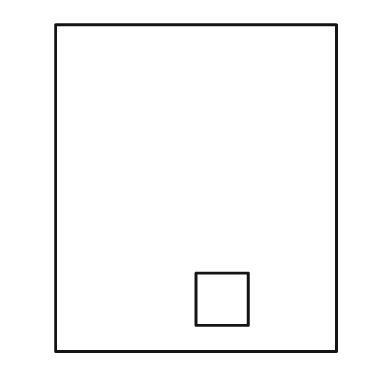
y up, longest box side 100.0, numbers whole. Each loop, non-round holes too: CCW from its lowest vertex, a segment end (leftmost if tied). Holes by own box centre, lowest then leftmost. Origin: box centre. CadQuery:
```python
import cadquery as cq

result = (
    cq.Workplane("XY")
    .moveTo(-43.0, -50.0)
    .lineTo(43.0, -50.0)
    .lineTo(43.0, 50.0)
    .lineTo(-43.0, 50.0)
    .close()
    .moveTo(0.0, -42.0)
    .lineTo(16.0, -42.0)
    .lineTo(16.0, -26.0)
    .lineTo(0.0, -26.0)
    .close()
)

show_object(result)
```